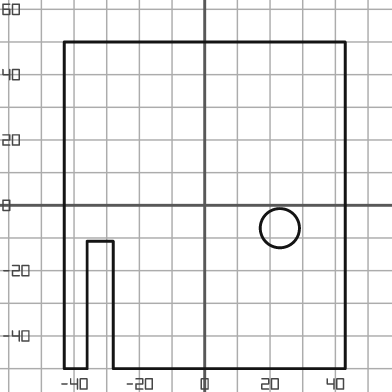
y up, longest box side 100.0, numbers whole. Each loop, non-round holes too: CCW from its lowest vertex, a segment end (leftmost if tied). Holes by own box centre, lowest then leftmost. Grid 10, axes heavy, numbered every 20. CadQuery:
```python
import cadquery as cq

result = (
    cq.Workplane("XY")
    .moveTo(-43.0, -50.0)
    .lineTo(-36.0, -50.0)
    .lineTo(-36.0, -11.0)
    .lineTo(-28.0, -11.0)
    .lineTo(-28.0, -50.0)
    .lineTo(43.0, -50.0)
    .lineTo(43.0, 50.0)
    .lineTo(-43.0, 50.0)
    .close()
    .moveTo(23.0, -7.0)
    .circle(6.0)
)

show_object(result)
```